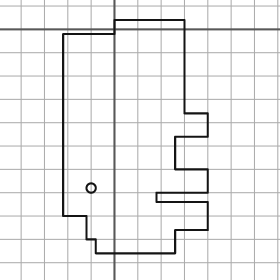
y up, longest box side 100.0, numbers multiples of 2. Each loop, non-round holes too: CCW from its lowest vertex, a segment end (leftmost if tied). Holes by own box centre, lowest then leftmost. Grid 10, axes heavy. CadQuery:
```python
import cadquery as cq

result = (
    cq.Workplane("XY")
    .moveTo(-8.0, -96.0)
    .lineTo(26.0, -96.0)
    .lineTo(26.0, -86.0)
    .lineTo(40.0, -86.0)
    .lineTo(40.0, -74.0)
    .lineTo(18.0, -74.0)
    .lineTo(18.0, -70.0)
    .lineTo(40.0, -70.0)
    .lineTo(40.0, -60.0)
    .lineTo(26.0, -60.0)
    .lineTo(26.0, -46.0)
    .lineTo(40.0, -46.0)
    .lineTo(40.0, -36.0)
    .lineTo(30.0, -36.0)
    .lineTo(30.0, 4.0)
    .lineTo(0.0, 4.0)
    .lineTo(0.0, -2.0)
    .lineTo(-22.0, -2.0)
    .lineTo(-22.0, -80.0)
    .lineTo(-12.0, -80.0)
    .lineTo(-12.0, -90.0)
    .lineTo(-8.0, -90.0)
    .close()
    .moveTo(-10.0, -68.0)
    .circle(2.0)
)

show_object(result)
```